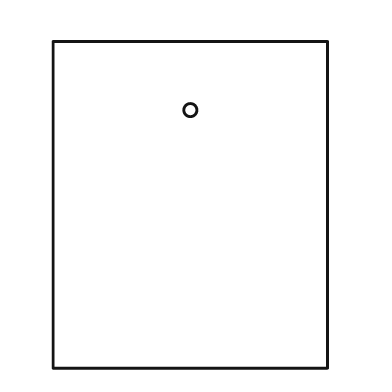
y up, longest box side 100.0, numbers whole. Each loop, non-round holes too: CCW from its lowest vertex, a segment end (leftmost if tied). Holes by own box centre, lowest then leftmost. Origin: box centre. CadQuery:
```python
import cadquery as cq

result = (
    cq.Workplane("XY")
    .moveTo(-42.0, -50.0)
    .lineTo(42.0, -50.0)
    .lineTo(42.0, 50.0)
    .lineTo(-42.0, 50.0)
    .close()
    .moveTo(0.0, 29.0)
    .circle(2.0)
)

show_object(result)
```